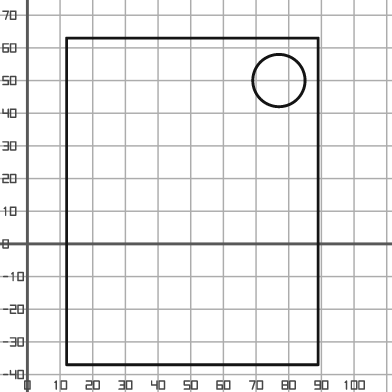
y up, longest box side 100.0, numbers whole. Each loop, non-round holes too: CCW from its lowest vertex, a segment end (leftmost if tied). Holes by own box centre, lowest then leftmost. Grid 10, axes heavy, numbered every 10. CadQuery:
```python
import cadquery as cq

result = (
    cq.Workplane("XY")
    .moveTo(12.0, -37.0)
    .lineTo(89.0, -37.0)
    .lineTo(89.0, 63.0)
    .lineTo(12.0, 63.0)
    .close()
    .moveTo(77.0, 50.0)
    .circle(8.0)
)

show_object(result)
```